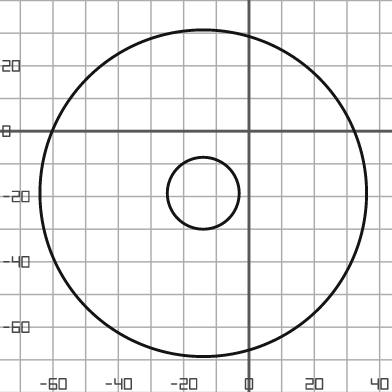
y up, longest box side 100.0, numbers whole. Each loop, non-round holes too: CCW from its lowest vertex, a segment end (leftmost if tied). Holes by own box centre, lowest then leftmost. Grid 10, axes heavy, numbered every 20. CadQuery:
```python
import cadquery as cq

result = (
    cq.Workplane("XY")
    .moveTo(-14.0, -19.0)
    .circle(50.0)
    .moveTo(-14.0, -19.0)
    .circle(11.0)
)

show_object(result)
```